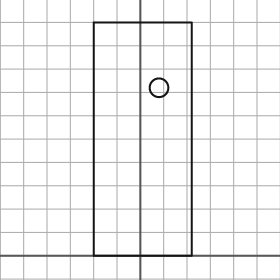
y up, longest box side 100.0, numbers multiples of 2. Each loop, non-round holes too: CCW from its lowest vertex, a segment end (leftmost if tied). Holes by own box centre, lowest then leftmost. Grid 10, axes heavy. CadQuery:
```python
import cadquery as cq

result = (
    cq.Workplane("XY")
    .moveTo(-20.0, 0.0)
    .lineTo(22.0, 0.0)
    .lineTo(22.0, 100.0)
    .lineTo(-20.0, 100.0)
    .close()
    .moveTo(8.0, 72.0)
    .circle(4.0)
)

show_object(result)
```